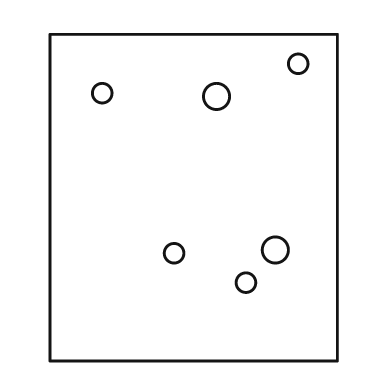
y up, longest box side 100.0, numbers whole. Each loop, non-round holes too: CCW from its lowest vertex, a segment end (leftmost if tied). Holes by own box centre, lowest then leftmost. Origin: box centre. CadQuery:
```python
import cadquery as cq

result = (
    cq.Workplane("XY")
    .moveTo(-44.0, -50.0)
    .lineTo(44.0, -50.0)
    .lineTo(44.0, 50.0)
    .lineTo(-44.0, 50.0)
    .close()
    .moveTo(16.0, -26.0)
    .circle(3.0)
    .moveTo(-6.0, -17.0)
    .circle(3.0)
    .moveTo(25.0, -16.0)
    .circle(4.0)
    .moveTo(7.0, 31.0)
    .circle(4.0)
    .moveTo(-28.0, 32.0)
    .circle(3.0)
    .moveTo(32.0, 41.0)
    .circle(3.0)
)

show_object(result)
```